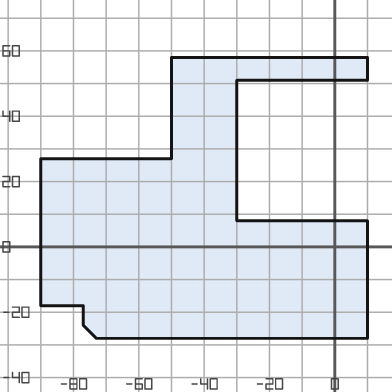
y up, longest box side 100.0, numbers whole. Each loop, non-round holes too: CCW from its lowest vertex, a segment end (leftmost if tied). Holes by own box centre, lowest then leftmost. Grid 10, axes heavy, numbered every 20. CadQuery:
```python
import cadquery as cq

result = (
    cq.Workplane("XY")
    .moveTo(-73.0, -28.0)
    .lineTo(10.0, -28.0)
    .lineTo(10.0, 8.0)
    .lineTo(-30.0, 8.0)
    .lineTo(-30.0, 51.0)
    .lineTo(10.0, 51.0)
    .lineTo(10.0, 58.0)
    .lineTo(-50.0, 58.0)
    .lineTo(-50.0, 27.0)
    .lineTo(-90.0, 27.0)
    .lineTo(-90.0, -18.0)
    .lineTo(-77.0, -18.0)
    .lineTo(-77.0, -24.0)
    .close()
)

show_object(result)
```